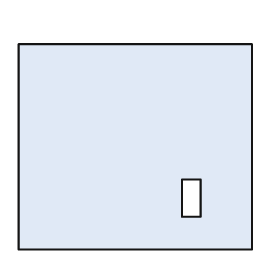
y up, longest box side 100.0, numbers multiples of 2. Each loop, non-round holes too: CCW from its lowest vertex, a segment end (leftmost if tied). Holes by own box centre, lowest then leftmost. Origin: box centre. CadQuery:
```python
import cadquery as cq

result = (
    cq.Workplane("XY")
    .moveTo(-50.0, -44.0)
    .lineTo(50.0, -44.0)
    .lineTo(50.0, 44.0)
    .lineTo(-50.0, 44.0)
    .close()
    .moveTo(20.0, -30.0)
    .lineTo(28.0, -30.0)
    .lineTo(28.0, -14.0)
    .lineTo(20.0, -14.0)
    .close()
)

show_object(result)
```